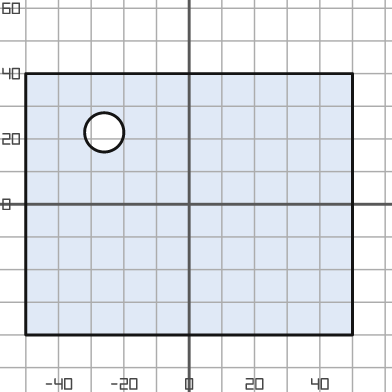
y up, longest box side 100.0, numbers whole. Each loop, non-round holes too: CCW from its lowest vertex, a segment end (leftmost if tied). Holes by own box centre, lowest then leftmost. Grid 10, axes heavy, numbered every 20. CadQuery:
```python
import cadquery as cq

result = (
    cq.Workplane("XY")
    .moveTo(-50.0, -40.0)
    .lineTo(50.0, -40.0)
    .lineTo(50.0, 40.0)
    .lineTo(-50.0, 40.0)
    .close()
    .moveTo(-26.0, 22.0)
    .circle(6.0)
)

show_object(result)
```